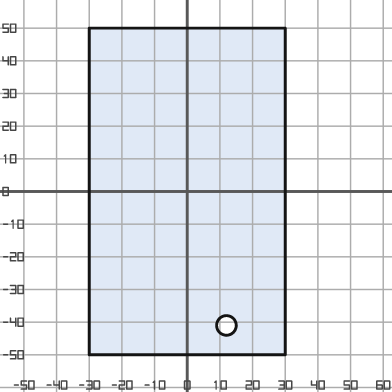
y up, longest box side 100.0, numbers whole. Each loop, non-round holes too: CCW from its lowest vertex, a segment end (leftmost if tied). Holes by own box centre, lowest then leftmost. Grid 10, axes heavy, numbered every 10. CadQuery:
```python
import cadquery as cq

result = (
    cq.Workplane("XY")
    .moveTo(-30.0, -50.0)
    .lineTo(30.0, -50.0)
    .lineTo(30.0, 50.0)
    .lineTo(-30.0, 50.0)
    .close()
    .moveTo(12.0, -41.0)
    .circle(3.0)
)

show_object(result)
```